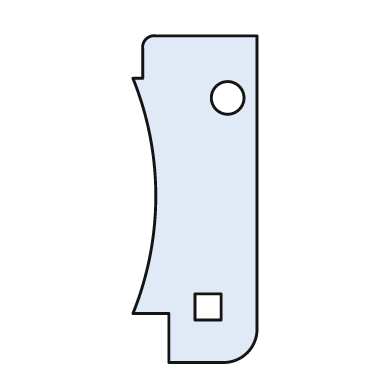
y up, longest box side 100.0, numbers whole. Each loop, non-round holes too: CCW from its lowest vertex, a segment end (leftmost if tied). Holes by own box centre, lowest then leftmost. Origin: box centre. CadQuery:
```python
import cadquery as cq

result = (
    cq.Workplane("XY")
    .moveTo(-8.0, -50.0)
    .lineTo(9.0, -50.0)
    .threePointArc((16.0, -47.0), (19.0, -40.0))
    .lineTo(19.0, 50.0)
    .lineTo(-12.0, 50.0)
    .threePointArc((-15.0, 49.0), (-16.0, 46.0))
    .lineTo(-16.0, 37.0)
    .lineTo(-19.0, 37.0)
    .threePointArc((-12.0, 1.0), (-19.0, -35.0))
    .lineTo(-8.0, -35.0)
    .close()
    .moveTo(0.0, -37.0)
    .lineTo(8.0, -37.0)
    .lineTo(8.0, -29.0)
    .lineTo(0.0, -29.0)
    .close()
    .moveTo(10.0, 31.0)
    .circle(5.0)
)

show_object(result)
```